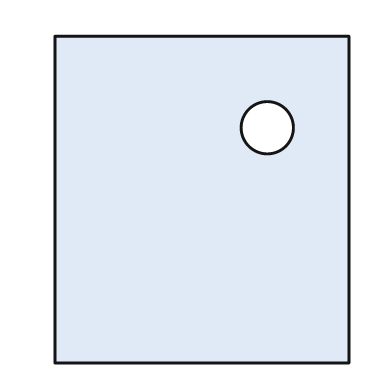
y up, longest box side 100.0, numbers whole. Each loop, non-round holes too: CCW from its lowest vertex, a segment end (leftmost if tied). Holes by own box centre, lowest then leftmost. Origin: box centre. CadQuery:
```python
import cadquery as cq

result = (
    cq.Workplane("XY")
    .moveTo(-45.0, -50.0)
    .lineTo(45.0, -50.0)
    .lineTo(45.0, 50.0)
    .lineTo(-45.0, 50.0)
    .close()
    .moveTo(20.0, 22.0)
    .circle(8.0)
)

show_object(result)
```